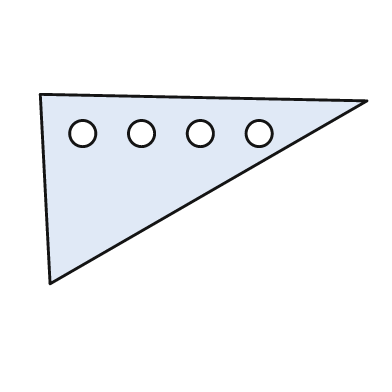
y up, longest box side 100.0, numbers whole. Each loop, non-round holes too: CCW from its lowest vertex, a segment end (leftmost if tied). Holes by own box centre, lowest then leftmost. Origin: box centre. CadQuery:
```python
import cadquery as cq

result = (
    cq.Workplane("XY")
    .moveTo(-47.0, -29.0)
    .lineTo(50.0, 27.0)
    .lineTo(-50.0, 29.0)
    .close()
    .moveTo(-37.0, 17.0)
    .circle(4.0)
    .moveTo(-19.0, 17.0)
    .circle(4.0)
    .moveTo(-1.0, 17.0)
    .circle(4.0)
    .moveTo(17.0, 17.0)
    .circle(4.0)
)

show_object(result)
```